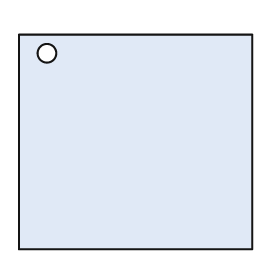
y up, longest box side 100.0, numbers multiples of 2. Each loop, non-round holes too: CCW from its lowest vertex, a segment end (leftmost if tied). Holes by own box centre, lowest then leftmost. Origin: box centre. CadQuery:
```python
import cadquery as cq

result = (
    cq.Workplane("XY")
    .moveTo(-50.0, -46.0)
    .lineTo(50.0, -46.0)
    .lineTo(50.0, 46.0)
    .lineTo(-50.0, 46.0)
    .close()
    .moveTo(-38.0, 38.0)
    .circle(4.0)
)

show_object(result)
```